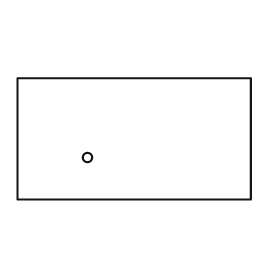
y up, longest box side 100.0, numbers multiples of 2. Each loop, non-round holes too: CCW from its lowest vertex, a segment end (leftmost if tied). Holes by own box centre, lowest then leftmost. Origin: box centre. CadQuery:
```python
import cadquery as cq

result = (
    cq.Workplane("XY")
    .moveTo(-50.0, -26.0)
    .lineTo(50.0, -26.0)
    .lineTo(50.0, 26.0)
    .lineTo(-50.0, 26.0)
    .close()
    .moveTo(-20.0, -8.0)
    .circle(2.0)
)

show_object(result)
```